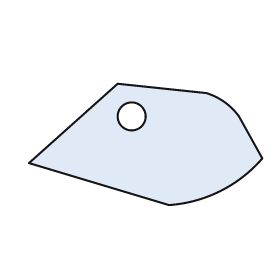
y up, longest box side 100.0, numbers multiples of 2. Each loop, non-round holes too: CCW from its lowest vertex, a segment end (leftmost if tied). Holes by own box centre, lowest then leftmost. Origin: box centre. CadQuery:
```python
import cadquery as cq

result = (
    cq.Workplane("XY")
    .moveTo(10.0, -26.0)
    .threePointArc((32.0, -20.0), (50.0, -6.0))
    .lineTo(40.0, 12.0)
    .threePointArc((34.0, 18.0), (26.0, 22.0))
    .lineTo(-12.0, 26.0)
    .lineTo(-50.0, -8.0)
    .close()
    .moveTo(-6.0, 12.0)
    .circle(6.0)
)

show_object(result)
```